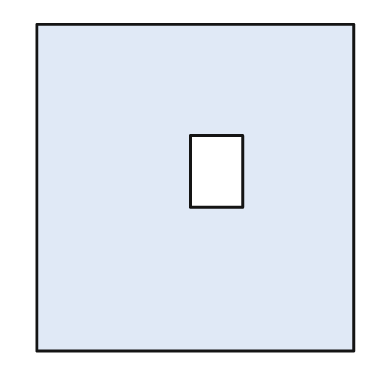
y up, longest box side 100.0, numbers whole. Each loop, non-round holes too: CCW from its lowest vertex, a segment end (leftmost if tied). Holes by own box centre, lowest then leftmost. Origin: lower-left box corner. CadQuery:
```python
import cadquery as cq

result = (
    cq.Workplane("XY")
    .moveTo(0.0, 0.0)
    .lineTo(97.0, 0.0)
    .lineTo(97.0, 100.0)
    .lineTo(0.0, 100.0)
    .close()
    .moveTo(47.0, 44.0)
    .lineTo(63.0, 44.0)
    .lineTo(63.0, 66.0)
    .lineTo(47.0, 66.0)
    .close()
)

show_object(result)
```